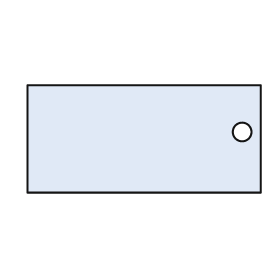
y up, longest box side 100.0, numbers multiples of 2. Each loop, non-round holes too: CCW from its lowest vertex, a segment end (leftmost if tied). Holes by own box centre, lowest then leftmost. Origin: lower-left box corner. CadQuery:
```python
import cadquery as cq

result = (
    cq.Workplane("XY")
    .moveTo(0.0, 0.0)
    .lineTo(100.0, 0.0)
    .lineTo(100.0, 46.0)
    .lineTo(0.0, 46.0)
    .close()
    .moveTo(92.0, 26.0)
    .circle(4.0)
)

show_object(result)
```